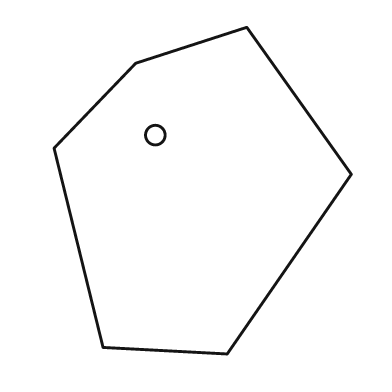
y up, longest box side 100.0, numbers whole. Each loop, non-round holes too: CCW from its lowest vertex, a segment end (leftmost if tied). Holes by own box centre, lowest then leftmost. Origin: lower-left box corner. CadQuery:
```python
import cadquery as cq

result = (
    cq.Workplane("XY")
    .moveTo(53.0, 0.0)
    .lineTo(91.0, 55.0)
    .lineTo(59.0, 100.0)
    .lineTo(25.0, 89.0)
    .lineTo(0.0, 63.0)
    .lineTo(15.0, 2.0)
    .close()
    .moveTo(31.0, 67.0)
    .circle(3.0)
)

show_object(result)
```